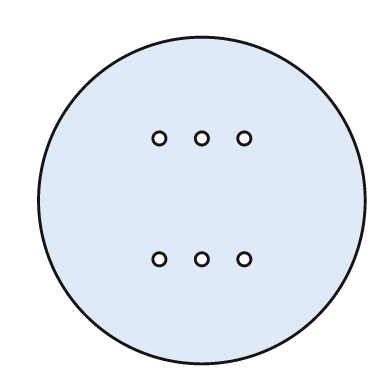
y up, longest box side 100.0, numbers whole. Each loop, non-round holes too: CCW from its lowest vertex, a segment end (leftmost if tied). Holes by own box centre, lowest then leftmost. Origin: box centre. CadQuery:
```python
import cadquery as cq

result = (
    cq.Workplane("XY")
    .moveTo(0.0, 0.0)
    .circle(50.0)
    .moveTo(-13.0, -18.0)
    .circle(2.0)
    .moveTo(0.0, -18.0)
    .circle(2.0)
    .moveTo(13.0, -18.0)
    .circle(2.0)
    .moveTo(-13.0, 19.0)
    .circle(2.0)
    .moveTo(0.0, 19.0)
    .circle(2.0)
    .moveTo(13.0, 19.0)
    .circle(2.0)
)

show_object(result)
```